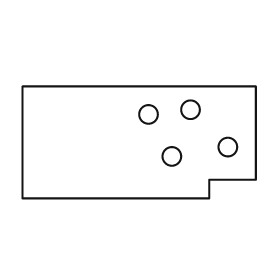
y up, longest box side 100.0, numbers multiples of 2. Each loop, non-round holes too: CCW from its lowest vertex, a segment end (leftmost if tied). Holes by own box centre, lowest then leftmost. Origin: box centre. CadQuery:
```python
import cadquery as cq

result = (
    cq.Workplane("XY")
    .moveTo(-50.0, -24.0)
    .lineTo(30.0, -24.0)
    .lineTo(30.0, -16.0)
    .lineTo(50.0, -16.0)
    .lineTo(50.0, 24.0)
    .lineTo(-50.0, 24.0)
    .close()
    .moveTo(14.0, -6.0)
    .circle(4.0)
    .moveTo(38.0, -2.0)
    .circle(4.0)
    .moveTo(4.0, 12.0)
    .circle(4.0)
    .moveTo(22.0, 14.0)
    .circle(4.0)
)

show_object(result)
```